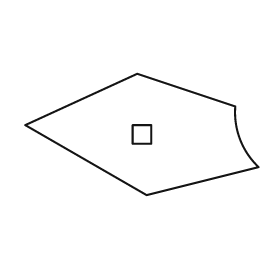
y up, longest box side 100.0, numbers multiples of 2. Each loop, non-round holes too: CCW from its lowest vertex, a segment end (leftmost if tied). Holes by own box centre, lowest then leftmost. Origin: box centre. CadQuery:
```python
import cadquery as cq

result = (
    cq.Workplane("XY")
    .moveTo(2.0, -26.0)
    .lineTo(50.0, -14.0)
    .threePointArc((42.0, -2.0), (40.0, 12.0))
    .lineTo(-2.0, 26.0)
    .lineTo(-50.0, 4.0)
    .close()
    .moveTo(-4.0, -4.0)
    .lineTo(4.0, -4.0)
    .lineTo(4.0, 4.0)
    .lineTo(-4.0, 4.0)
    .close()
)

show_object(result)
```